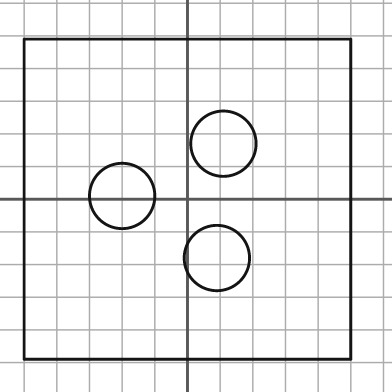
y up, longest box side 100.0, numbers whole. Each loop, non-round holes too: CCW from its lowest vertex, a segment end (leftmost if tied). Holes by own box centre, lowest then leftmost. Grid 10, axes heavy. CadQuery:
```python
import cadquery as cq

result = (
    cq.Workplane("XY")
    .moveTo(-50.0, -49.0)
    .lineTo(50.0, -49.0)
    .lineTo(50.0, 49.0)
    .lineTo(-50.0, 49.0)
    .close()
    .moveTo(9.0, -18.0)
    .circle(10.0)
    .moveTo(-20.0, 1.0)
    .circle(10.0)
    .moveTo(11.0, 17.0)
    .circle(10.0)
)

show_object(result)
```